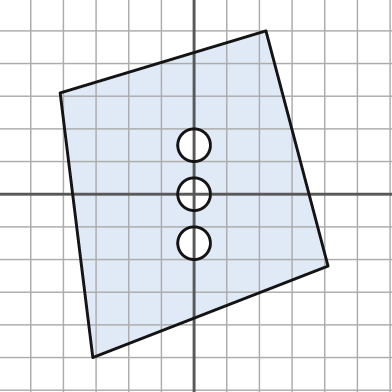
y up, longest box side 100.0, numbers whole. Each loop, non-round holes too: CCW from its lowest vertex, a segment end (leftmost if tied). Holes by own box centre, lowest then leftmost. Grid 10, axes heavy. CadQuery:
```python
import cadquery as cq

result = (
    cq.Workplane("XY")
    .moveTo(-31.0, -50.0)
    .lineTo(41.0, -22.0)
    .lineTo(22.0, 50.0)
    .lineTo(-41.0, 31.0)
    .close()
    .moveTo(0.0, -15.0)
    .circle(5.0)
    .moveTo(0.0, 0.0)
    .circle(5.0)
    .moveTo(0.0, 15.0)
    .circle(5.0)
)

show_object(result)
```